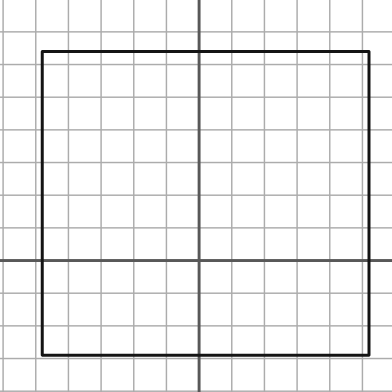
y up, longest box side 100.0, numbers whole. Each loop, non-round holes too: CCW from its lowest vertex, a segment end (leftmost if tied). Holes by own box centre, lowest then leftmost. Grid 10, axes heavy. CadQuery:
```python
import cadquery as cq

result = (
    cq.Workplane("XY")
    .moveTo(-48.0, -29.0)
    .lineTo(52.0, -29.0)
    .lineTo(52.0, 64.0)
    .lineTo(-48.0, 64.0)
    .close()
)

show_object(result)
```